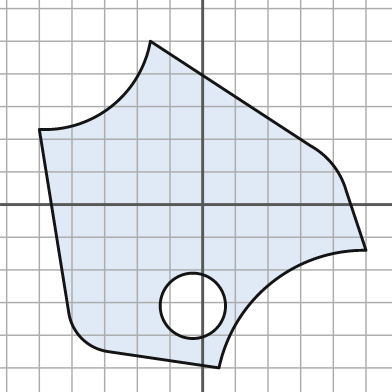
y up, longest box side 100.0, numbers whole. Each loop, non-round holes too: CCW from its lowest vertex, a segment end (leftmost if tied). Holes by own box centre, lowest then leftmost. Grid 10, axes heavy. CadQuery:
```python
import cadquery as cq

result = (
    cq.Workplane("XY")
    .moveTo(5.0, -50.0)
    .threePointArc((21.0, -24.0), (50.0, -14.0))
    .lineTo(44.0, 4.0)
    .threePointArc((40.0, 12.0), (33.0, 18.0))
    .lineTo(-16.0, 50.0)
    .threePointArc((-28.0, 30.0), (-50.0, 23.0))
    .lineTo(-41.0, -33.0)
    .threePointArc((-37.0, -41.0), (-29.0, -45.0))
    .close()
    .moveTo(-3.0, -31.0)
    .circle(10.0)
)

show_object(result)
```